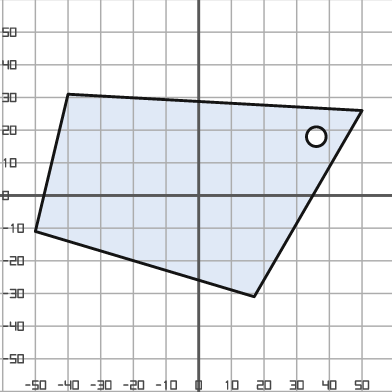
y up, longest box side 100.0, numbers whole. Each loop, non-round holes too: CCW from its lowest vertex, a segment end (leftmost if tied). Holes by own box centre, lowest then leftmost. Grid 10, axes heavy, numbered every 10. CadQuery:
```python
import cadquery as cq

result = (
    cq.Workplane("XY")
    .moveTo(17.0, -31.0)
    .lineTo(50.0, 26.0)
    .lineTo(-40.0, 31.0)
    .lineTo(-50.0, -11.0)
    .close()
    .moveTo(36.0, 18.0)
    .circle(3.0)
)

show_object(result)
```